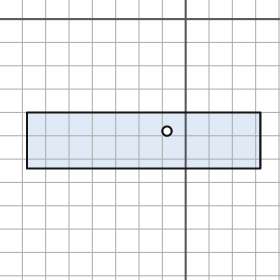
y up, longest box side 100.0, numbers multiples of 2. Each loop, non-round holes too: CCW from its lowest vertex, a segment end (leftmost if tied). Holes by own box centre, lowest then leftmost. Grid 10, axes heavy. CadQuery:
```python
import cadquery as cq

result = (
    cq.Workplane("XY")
    .moveTo(-68.0, -64.0)
    .lineTo(32.0, -64.0)
    .lineTo(32.0, -40.0)
    .lineTo(-68.0, -40.0)
    .close()
    .moveTo(-8.0, -48.0)
    .circle(2.0)
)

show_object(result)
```